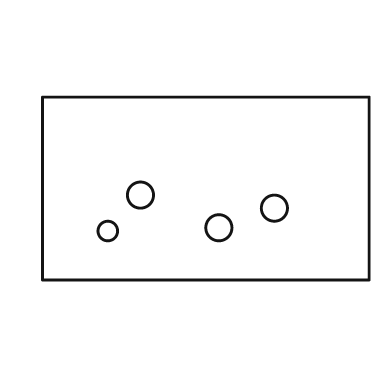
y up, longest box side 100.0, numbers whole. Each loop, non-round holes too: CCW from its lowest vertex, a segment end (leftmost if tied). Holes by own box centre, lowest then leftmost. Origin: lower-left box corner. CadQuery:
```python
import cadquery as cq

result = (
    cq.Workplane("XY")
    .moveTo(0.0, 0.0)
    .lineTo(100.0, 0.0)
    .lineTo(100.0, 56.0)
    .lineTo(0.0, 56.0)
    .close()
    .moveTo(20.0, 15.0)
    .circle(3.0)
    .moveTo(54.0, 16.0)
    .circle(4.0)
    .moveTo(71.0, 22.0)
    .circle(4.0)
    .moveTo(30.0, 26.0)
    .circle(4.0)
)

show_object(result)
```